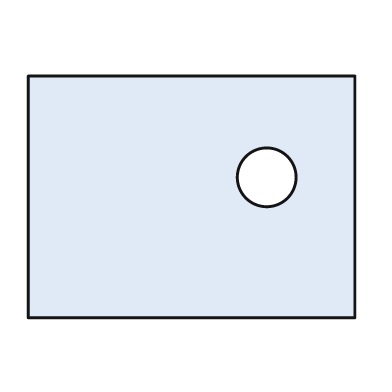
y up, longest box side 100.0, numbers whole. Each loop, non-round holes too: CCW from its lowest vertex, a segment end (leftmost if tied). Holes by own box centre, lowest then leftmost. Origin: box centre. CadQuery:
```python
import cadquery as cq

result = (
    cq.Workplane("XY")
    .moveTo(-50.0, -37.0)
    .lineTo(50.0, -37.0)
    .lineTo(50.0, 37.0)
    .lineTo(-50.0, 37.0)
    .close()
    .moveTo(23.0, 6.0)
    .circle(9.0)
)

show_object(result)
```